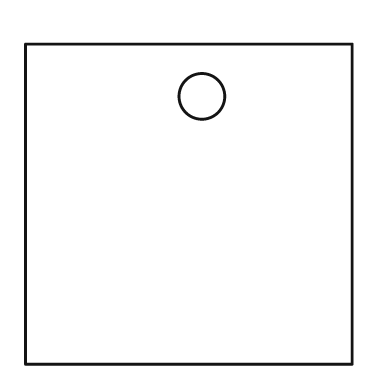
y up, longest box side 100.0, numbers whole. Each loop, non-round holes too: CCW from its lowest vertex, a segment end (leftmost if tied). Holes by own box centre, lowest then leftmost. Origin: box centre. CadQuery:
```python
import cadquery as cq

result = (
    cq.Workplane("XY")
    .moveTo(-50.0, -49.0)
    .lineTo(50.0, -49.0)
    .lineTo(50.0, 49.0)
    .lineTo(-50.0, 49.0)
    .close()
    .moveTo(4.0, 33.0)
    .circle(7.0)
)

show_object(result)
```